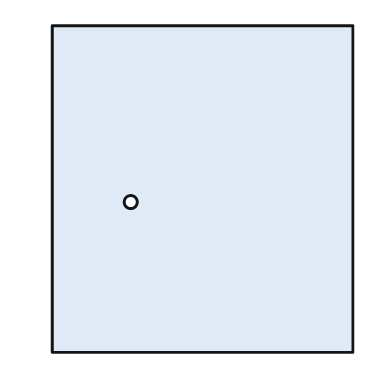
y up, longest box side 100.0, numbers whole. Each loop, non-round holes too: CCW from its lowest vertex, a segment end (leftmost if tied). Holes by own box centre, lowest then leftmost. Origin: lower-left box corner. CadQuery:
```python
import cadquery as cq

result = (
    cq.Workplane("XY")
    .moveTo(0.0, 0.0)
    .lineTo(92.0, 0.0)
    .lineTo(92.0, 100.0)
    .lineTo(0.0, 100.0)
    .close()
    .moveTo(24.0, 46.0)
    .circle(2.0)
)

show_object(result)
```